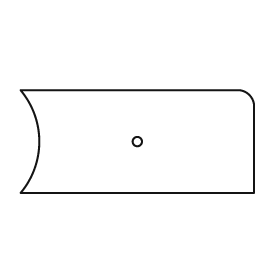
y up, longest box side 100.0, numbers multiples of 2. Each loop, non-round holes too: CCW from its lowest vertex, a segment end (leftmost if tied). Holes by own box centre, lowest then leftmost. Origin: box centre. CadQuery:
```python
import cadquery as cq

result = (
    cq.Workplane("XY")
    .moveTo(-50.0, -22.0)
    .lineTo(50.0, -22.0)
    .lineTo(50.0, 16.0)
    .threePointArc((48.0, 20.0), (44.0, 22.0))
    .lineTo(-50.0, 22.0)
    .threePointArc((-42.0, 0.0), (-50.0, -22.0))
    .close()
    .moveTo(0.0, 0.0)
    .circle(2.0)
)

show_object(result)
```